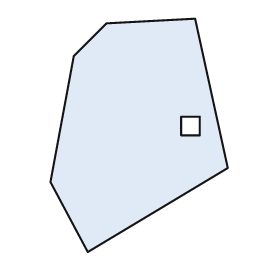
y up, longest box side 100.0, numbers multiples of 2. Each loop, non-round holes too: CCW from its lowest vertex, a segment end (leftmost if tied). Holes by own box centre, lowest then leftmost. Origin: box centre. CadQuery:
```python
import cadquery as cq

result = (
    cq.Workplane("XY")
    .moveTo(-22.0, -50.0)
    .lineTo(38.0, -14.0)
    .lineTo(24.0, 50.0)
    .lineTo(-14.0, 48.0)
    .lineTo(-28.0, 34.0)
    .lineTo(-38.0, -20.0)
    .close()
    .moveTo(18.0, 0.0)
    .lineTo(26.0, 0.0)
    .lineTo(26.0, 8.0)
    .lineTo(18.0, 8.0)
    .close()
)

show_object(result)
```